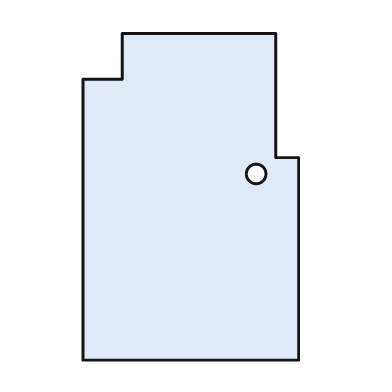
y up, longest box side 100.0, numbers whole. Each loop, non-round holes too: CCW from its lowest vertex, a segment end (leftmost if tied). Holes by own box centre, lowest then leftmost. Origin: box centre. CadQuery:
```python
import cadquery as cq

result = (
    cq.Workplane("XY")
    .moveTo(-33.0, -50.0)
    .lineTo(33.0, -50.0)
    .lineTo(33.0, 12.0)
    .lineTo(26.0, 12.0)
    .lineTo(26.0, 50.0)
    .lineTo(-21.0, 50.0)
    .lineTo(-21.0, 36.0)
    .lineTo(-33.0, 36.0)
    .close()
    .moveTo(20.0, 7.0)
    .circle(3.0)
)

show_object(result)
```